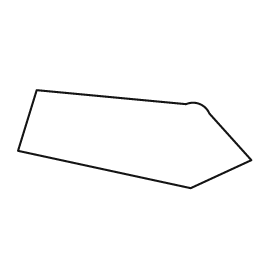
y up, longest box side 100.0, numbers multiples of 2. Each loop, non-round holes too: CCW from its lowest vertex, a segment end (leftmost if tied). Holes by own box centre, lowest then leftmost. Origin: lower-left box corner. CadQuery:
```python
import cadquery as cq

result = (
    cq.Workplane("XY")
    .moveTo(74.0, 0.0)
    .lineTo(100.0, 12.0)
    .lineTo(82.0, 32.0)
    .threePointArc((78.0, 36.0), (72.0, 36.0))
    .lineTo(8.0, 42.0)
    .lineTo(0.0, 16.0)
    .close()
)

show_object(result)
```